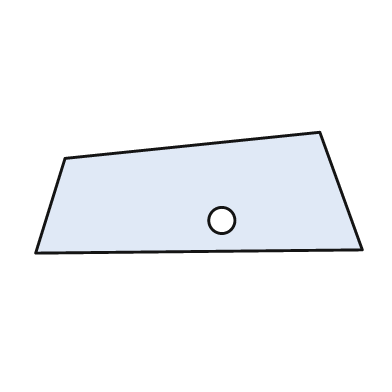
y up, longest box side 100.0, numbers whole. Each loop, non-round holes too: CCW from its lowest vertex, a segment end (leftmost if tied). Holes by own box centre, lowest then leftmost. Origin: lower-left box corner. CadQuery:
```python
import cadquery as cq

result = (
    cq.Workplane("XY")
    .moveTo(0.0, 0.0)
    .lineTo(100.0, 1.0)
    .lineTo(87.0, 37.0)
    .lineTo(9.0, 29.0)
    .close()
    .moveTo(57.0, 10.0)
    .circle(4.0)
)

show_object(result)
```